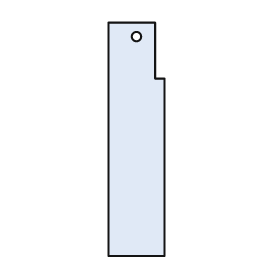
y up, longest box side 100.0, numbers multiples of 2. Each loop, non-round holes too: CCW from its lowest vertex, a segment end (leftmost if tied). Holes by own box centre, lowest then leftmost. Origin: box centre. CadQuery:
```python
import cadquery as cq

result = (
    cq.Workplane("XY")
    .moveTo(-12.0, -50.0)
    .lineTo(12.0, -50.0)
    .lineTo(12.0, 26.0)
    .lineTo(8.0, 26.0)
    .lineTo(8.0, 50.0)
    .lineTo(-12.0, 50.0)
    .close()
    .moveTo(0.0, 44.0)
    .circle(2.0)
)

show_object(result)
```